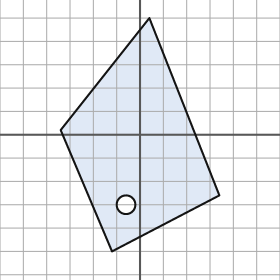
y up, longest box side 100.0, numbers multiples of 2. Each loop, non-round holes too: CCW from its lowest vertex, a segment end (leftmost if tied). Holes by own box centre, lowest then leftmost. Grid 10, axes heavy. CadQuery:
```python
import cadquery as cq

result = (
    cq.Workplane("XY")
    .moveTo(-12.0, -50.0)
    .lineTo(34.0, -26.0)
    .lineTo(4.0, 50.0)
    .lineTo(-34.0, 2.0)
    .close()
    .moveTo(-6.0, -30.0)
    .circle(4.0)
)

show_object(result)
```